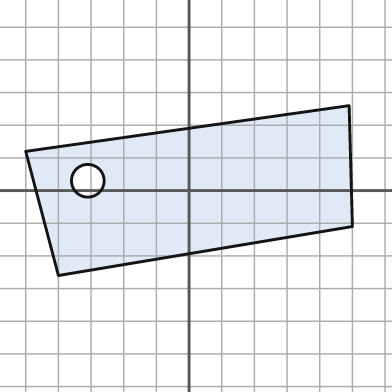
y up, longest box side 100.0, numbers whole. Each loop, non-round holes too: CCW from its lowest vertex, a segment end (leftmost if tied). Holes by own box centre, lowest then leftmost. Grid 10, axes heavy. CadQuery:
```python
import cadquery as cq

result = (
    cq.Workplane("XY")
    .moveTo(-40.0, -26.0)
    .lineTo(50.0, -11.0)
    .lineTo(49.0, 26.0)
    .lineTo(-50.0, 12.0)
    .close()
    .moveTo(-31.0, 3.0)
    .circle(5.0)
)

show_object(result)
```